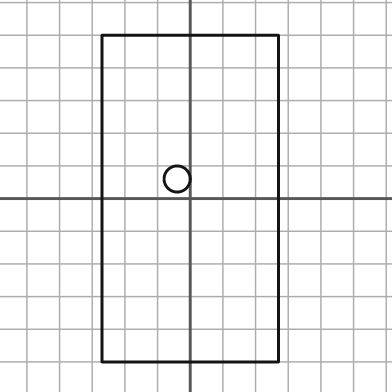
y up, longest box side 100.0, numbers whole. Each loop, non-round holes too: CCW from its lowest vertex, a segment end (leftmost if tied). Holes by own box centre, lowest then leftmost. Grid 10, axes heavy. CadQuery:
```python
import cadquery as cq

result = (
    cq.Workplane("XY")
    .moveTo(-27.0, -50.0)
    .lineTo(27.0, -50.0)
    .lineTo(27.0, 50.0)
    .lineTo(-27.0, 50.0)
    .close()
    .moveTo(-4.0, 6.0)
    .circle(4.0)
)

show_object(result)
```